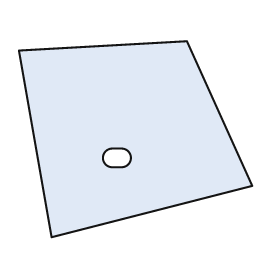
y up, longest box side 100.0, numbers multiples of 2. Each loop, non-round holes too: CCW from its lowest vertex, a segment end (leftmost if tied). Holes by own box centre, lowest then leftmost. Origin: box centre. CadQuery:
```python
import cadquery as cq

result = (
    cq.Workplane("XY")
    .moveTo(-36.0, -42.0)
    .lineTo(50.0, -20.0)
    .lineTo(22.0, 42.0)
    .lineTo(-50.0, 38.0)
    .close()
    .moveTo(-10.0, -12.0)
    .lineTo(-6.0, -12.0)
    .threePointArc((-2.0, -8.0), (-6.0, -4.0))
    .lineTo(-10.0, -4.0)
    .threePointArc((-14.0, -8.0), (-10.0, -12.0))
    .close()
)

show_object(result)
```